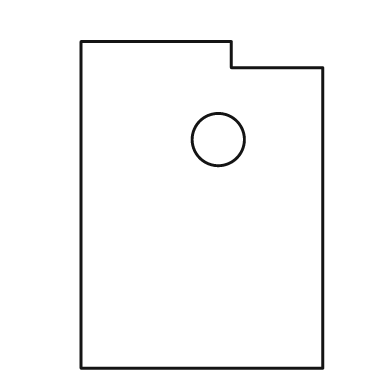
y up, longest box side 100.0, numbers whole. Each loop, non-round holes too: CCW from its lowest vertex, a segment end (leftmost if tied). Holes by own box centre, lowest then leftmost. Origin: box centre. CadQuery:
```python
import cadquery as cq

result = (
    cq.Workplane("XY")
    .moveTo(-37.0, -50.0)
    .lineTo(37.0, -50.0)
    .lineTo(37.0, 42.0)
    .lineTo(9.0, 42.0)
    .lineTo(9.0, 50.0)
    .lineTo(-37.0, 50.0)
    .close()
    .moveTo(5.0, 20.0)
    .circle(8.0)
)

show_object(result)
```